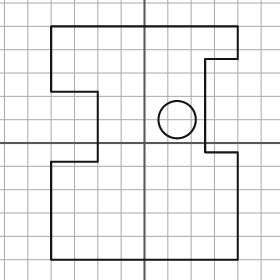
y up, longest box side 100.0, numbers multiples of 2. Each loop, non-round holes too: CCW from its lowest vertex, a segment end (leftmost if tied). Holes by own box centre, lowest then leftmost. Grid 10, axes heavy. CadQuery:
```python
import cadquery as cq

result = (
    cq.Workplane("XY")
    .moveTo(-40.0, -50.0)
    .lineTo(40.0, -50.0)
    .lineTo(40.0, -4.0)
    .lineTo(26.0, -4.0)
    .lineTo(26.0, 36.0)
    .lineTo(40.0, 36.0)
    .lineTo(40.0, 50.0)
    .lineTo(-40.0, 50.0)
    .lineTo(-40.0, 22.0)
    .lineTo(-20.0, 22.0)
    .lineTo(-20.0, -8.0)
    .lineTo(-40.0, -8.0)
    .close()
    .moveTo(14.0, 10.0)
    .circle(8.0)
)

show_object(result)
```